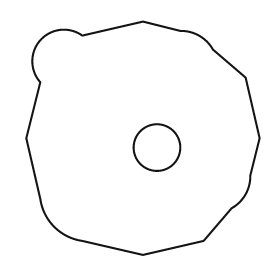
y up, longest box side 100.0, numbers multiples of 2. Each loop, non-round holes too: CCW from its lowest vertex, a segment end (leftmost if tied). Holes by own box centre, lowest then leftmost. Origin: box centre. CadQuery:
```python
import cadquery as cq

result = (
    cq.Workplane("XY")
    .moveTo(0.0, -50.0)
    .lineTo(26.0, -44.0)
    .lineTo(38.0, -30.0)
    .threePointArc((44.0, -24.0), (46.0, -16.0))
    .lineTo(50.0, 0.0)
    .lineTo(44.0, 26.0)
    .lineTo(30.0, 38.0)
    .threePointArc((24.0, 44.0), (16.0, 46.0))
    .lineTo(0.0, 50.0)
    .lineTo(-26.0, 44.0)
    .threePointArc((-44.0, 42.0), (-44.0, 24.0))
    .lineTo(-50.0, 0.0)
    .lineTo(-44.0, -26.0)
    .threePointArc((-38.0, -38.0), (-26.0, -44.0))
    .close()
    .moveTo(6.0, -4.0)
    .circle(10.0)
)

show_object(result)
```